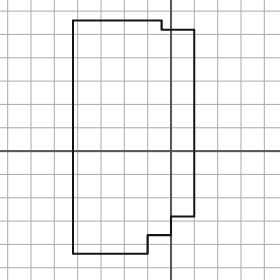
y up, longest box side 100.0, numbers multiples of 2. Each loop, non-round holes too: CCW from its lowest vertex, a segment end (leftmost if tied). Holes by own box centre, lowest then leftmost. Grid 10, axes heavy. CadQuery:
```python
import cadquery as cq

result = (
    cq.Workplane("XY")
    .moveTo(-42.0, -44.0)
    .lineTo(-10.0, -44.0)
    .lineTo(-10.0, -36.0)
    .lineTo(0.0, -36.0)
    .lineTo(0.0, -28.0)
    .lineTo(10.0, -28.0)
    .lineTo(10.0, 52.0)
    .lineTo(-4.0, 52.0)
    .lineTo(-4.0, 56.0)
    .lineTo(-42.0, 56.0)
    .close()
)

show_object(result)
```